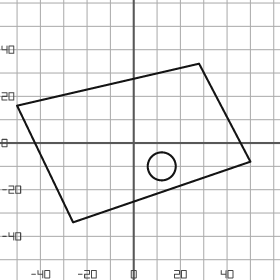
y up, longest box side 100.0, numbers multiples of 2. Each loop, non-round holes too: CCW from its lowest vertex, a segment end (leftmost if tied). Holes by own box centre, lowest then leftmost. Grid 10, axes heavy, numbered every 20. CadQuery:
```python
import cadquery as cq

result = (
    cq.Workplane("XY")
    .moveTo(-26.0, -34.0)
    .lineTo(50.0, -8.0)
    .lineTo(28.0, 34.0)
    .lineTo(-50.0, 16.0)
    .close()
    .moveTo(12.0, -10.0)
    .circle(6.0)
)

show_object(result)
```